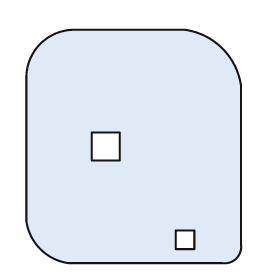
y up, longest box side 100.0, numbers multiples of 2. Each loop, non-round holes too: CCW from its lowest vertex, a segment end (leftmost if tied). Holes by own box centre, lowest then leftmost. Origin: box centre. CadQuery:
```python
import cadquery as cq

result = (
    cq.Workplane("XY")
    .moveTo(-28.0, -50.0)
    .lineTo(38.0, -50.0)
    .threePointArc((44.0, -48.0), (46.0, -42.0))
    .lineTo(46.0, 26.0)
    .threePointArc((38.0, 42.0), (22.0, 50.0))
    .lineTo(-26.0, 50.0)
    .threePointArc((-40.0, 44.0), (-46.0, 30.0))
    .lineTo(-46.0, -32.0)
    .threePointArc((-40.0, -44.0), (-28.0, -50.0))
    .close()
    .moveTo(18.0, -44.0)
    .lineTo(26.0, -44.0)
    .lineTo(26.0, -36.0)
    .lineTo(18.0, -36.0)
    .close()
    .moveTo(-18.0, -6.0)
    .lineTo(-6.0, -6.0)
    .lineTo(-6.0, 6.0)
    .lineTo(-18.0, 6.0)
    .close()
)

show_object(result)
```